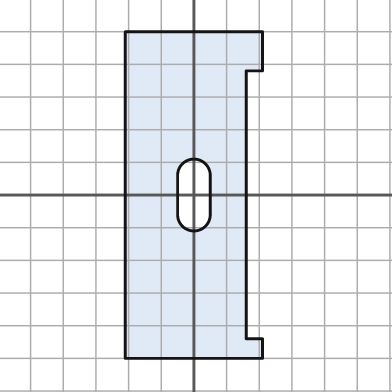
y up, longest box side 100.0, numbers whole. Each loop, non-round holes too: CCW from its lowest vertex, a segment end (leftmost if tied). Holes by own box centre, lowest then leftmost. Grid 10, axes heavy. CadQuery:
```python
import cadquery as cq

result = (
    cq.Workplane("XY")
    .moveTo(-21.0, -50.0)
    .lineTo(21.0, -50.0)
    .lineTo(21.0, -44.0)
    .lineTo(16.0, -44.0)
    .lineTo(16.0, 38.0)
    .lineTo(21.0, 38.0)
    .lineTo(21.0, 50.0)
    .lineTo(-21.0, 50.0)
    .close()
    .moveTo(-5.0, -6.0)
    .threePointArc((0.0, -11.0), (5.0, -6.0))
    .lineTo(5.0, 6.0)
    .threePointArc((0.0, 11.0), (-5.0, 6.0))
    .close()
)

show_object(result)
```